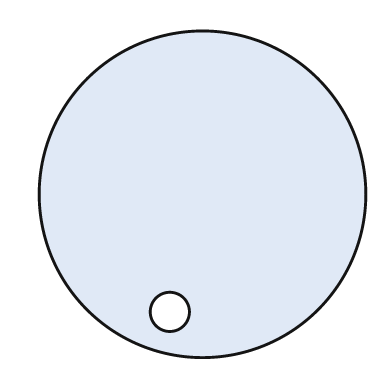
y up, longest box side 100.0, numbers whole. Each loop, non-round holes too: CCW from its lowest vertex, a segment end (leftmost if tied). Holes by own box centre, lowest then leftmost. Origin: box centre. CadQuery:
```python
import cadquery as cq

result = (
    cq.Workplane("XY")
    .moveTo(0.0, 0.0)
    .circle(50.0)
    .moveTo(-10.0, -36.0)
    .circle(6.0)
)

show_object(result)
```